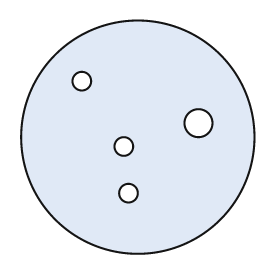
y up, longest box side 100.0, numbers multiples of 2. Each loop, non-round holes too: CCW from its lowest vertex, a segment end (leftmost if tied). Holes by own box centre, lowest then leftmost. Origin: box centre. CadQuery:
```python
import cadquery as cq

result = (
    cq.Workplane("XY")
    .moveTo(0.0, 0.0)
    .circle(50.0)
    .moveTo(-4.0, -24.0)
    .circle(4.0)
    .moveTo(-6.0, -4.0)
    .circle(4.0)
    .moveTo(26.0, 6.0)
    .circle(6.0)
    .moveTo(-24.0, 24.0)
    .circle(4.0)
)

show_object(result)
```